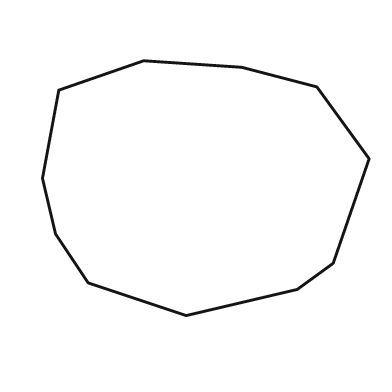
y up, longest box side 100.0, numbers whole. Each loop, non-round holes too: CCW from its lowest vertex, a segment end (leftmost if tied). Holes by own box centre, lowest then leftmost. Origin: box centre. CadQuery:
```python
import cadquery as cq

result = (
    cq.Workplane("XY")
    .moveTo(-6.0, -39.0)
    .lineTo(28.0, -31.0)
    .lineTo(39.0, -23.0)
    .lineTo(50.0, 9.0)
    .lineTo(34.0, 31.0)
    .lineTo(11.0, 37.0)
    .lineTo(-19.0, 39.0)
    .lineTo(-45.0, 30.0)
    .lineTo(-50.0, 3.0)
    .lineTo(-46.0, -14.0)
    .lineTo(-36.0, -29.0)
    .close()
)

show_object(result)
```